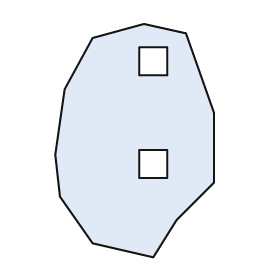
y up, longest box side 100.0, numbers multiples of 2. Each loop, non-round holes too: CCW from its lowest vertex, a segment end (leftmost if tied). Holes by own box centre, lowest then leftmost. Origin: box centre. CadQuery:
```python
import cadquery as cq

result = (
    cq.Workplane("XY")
    .moveTo(8.0, -50.0)
    .lineTo(18.0, -34.0)
    .lineTo(34.0, -18.0)
    .lineTo(34.0, 12.0)
    .lineTo(22.0, 46.0)
    .lineTo(4.0, 50.0)
    .lineTo(-18.0, 44.0)
    .lineTo(-30.0, 22.0)
    .lineTo(-34.0, -6.0)
    .lineTo(-32.0, -24.0)
    .lineTo(-18.0, -44.0)
    .close()
    .moveTo(2.0, -16.0)
    .lineTo(14.0, -16.0)
    .lineTo(14.0, -4.0)
    .lineTo(2.0, -4.0)
    .close()
    .moveTo(2.0, 28.0)
    .lineTo(14.0, 28.0)
    .lineTo(14.0, 40.0)
    .lineTo(2.0, 40.0)
    .close()
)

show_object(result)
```